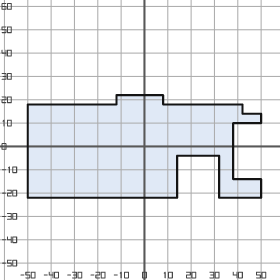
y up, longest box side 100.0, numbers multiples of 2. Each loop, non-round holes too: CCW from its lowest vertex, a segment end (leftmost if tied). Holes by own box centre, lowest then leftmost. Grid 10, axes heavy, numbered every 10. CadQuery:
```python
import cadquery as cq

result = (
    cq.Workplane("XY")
    .moveTo(-50.0, -22.0)
    .lineTo(14.0, -22.0)
    .lineTo(14.0, -4.0)
    .lineTo(32.0, -4.0)
    .lineTo(32.0, -22.0)
    .lineTo(50.0, -22.0)
    .lineTo(50.0, -14.0)
    .lineTo(38.0, -14.0)
    .lineTo(38.0, 10.0)
    .lineTo(50.0, 10.0)
    .lineTo(50.0, 14.0)
    .lineTo(42.0, 14.0)
    .lineTo(42.0, 18.0)
    .lineTo(8.0, 18.0)
    .lineTo(8.0, 22.0)
    .lineTo(-12.0, 22.0)
    .lineTo(-12.0, 18.0)
    .lineTo(-50.0, 18.0)
    .close()
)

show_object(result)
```